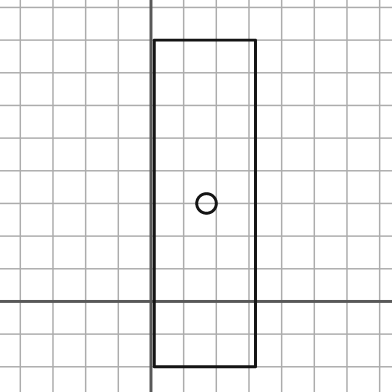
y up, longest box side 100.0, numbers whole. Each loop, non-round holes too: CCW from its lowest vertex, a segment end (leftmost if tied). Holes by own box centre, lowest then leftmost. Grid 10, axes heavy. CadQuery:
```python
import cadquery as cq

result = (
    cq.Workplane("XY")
    .moveTo(1.0, -20.0)
    .lineTo(32.0, -20.0)
    .lineTo(32.0, 80.0)
    .lineTo(1.0, 80.0)
    .close()
    .moveTo(17.0, 30.0)
    .circle(3.0)
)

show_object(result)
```